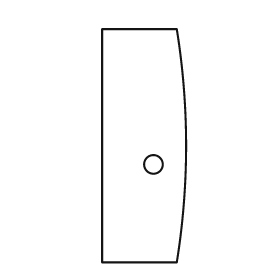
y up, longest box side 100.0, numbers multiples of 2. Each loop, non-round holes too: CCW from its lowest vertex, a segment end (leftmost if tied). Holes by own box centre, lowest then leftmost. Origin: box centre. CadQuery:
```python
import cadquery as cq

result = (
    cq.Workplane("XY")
    .moveTo(-18.0, -50.0)
    .lineTo(14.0, -50.0)
    .threePointArc((18.0, 0.0), (14.0, 50.0))
    .lineTo(-18.0, 50.0)
    .close()
    .moveTo(4.0, -8.0)
    .circle(4.0)
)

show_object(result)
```